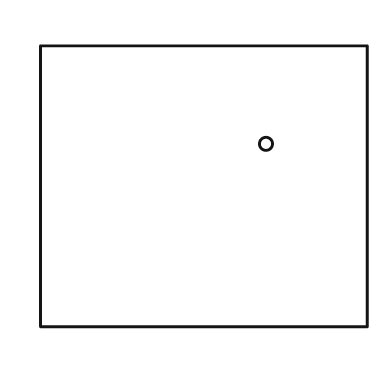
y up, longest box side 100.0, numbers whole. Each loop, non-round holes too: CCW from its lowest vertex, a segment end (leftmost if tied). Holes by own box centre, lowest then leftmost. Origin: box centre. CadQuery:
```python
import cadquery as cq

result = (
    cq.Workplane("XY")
    .moveTo(-50.0, -43.0)
    .lineTo(50.0, -43.0)
    .lineTo(50.0, 43.0)
    .lineTo(-50.0, 43.0)
    .close()
    .moveTo(19.0, 13.0)
    .circle(2.0)
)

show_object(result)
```